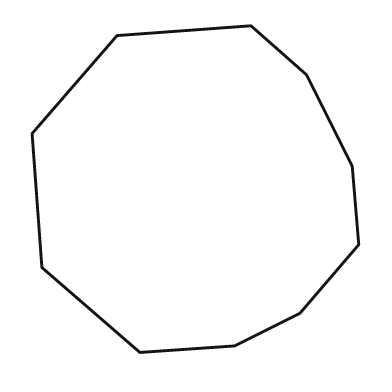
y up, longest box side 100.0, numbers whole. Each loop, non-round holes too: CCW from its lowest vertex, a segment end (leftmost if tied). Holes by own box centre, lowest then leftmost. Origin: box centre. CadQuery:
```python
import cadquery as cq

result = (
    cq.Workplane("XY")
    .moveTo(-17.0, -50.0)
    .lineTo(12.0, -48.0)
    .lineTo(32.0, -38.0)
    .lineTo(50.0, -17.0)
    .lineTo(48.0, 7.0)
    .lineTo(34.0, 35.0)
    .lineTo(17.0, 50.0)
    .lineTo(-24.0, 47.0)
    .lineTo(-50.0, 17.0)
    .lineTo(-47.0, -24.0)
    .close()
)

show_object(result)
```